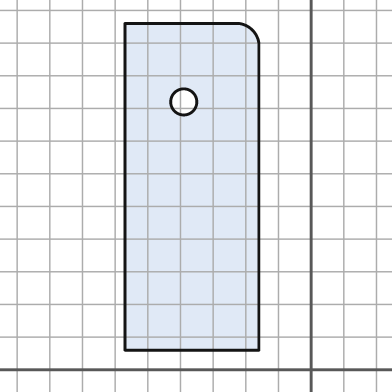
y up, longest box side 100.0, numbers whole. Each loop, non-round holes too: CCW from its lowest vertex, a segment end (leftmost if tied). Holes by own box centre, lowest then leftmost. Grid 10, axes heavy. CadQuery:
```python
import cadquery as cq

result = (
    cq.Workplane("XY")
    .moveTo(-57.0, 6.0)
    .lineTo(-16.0, 6.0)
    .lineTo(-16.0, 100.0)
    .threePointArc((-18.0, 104.0), (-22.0, 106.0))
    .lineTo(-57.0, 106.0)
    .close()
    .moveTo(-39.0, 82.0)
    .circle(4.0)
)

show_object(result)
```